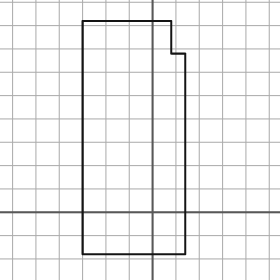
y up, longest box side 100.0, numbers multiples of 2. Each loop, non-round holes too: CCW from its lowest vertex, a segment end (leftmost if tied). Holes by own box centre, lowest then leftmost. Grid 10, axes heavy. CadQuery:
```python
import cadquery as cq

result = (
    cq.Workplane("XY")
    .moveTo(-30.0, -18.0)
    .lineTo(14.0, -18.0)
    .lineTo(14.0, 68.0)
    .lineTo(8.0, 68.0)
    .lineTo(8.0, 82.0)
    .lineTo(-30.0, 82.0)
    .close()
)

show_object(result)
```